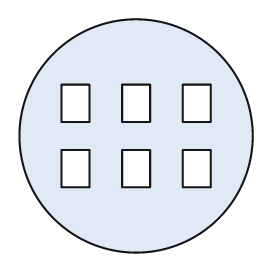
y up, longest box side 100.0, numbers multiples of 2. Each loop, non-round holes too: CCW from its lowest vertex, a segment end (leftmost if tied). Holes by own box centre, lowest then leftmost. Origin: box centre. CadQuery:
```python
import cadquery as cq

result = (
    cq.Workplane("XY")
    .moveTo(0.0, 0.0)
    .circle(50.0)
    .moveTo(-32.0, -22.0)
    .lineTo(-20.0, -22.0)
    .lineTo(-20.0, -6.0)
    .lineTo(-32.0, -6.0)
    .close()
    .moveTo(-6.0, -22.0)
    .lineTo(6.0, -22.0)
    .lineTo(6.0, -6.0)
    .lineTo(-6.0, -6.0)
    .close()
    .moveTo(20.0, -22.0)
    .lineTo(32.0, -22.0)
    .lineTo(32.0, -6.0)
    .lineTo(20.0, -6.0)
    .close()
    .moveTo(-32.0, 6.0)
    .lineTo(-20.0, 6.0)
    .lineTo(-20.0, 22.0)
    .lineTo(-32.0, 22.0)
    .close()
    .moveTo(-6.0, 6.0)
    .lineTo(6.0, 6.0)
    .lineTo(6.0, 22.0)
    .lineTo(-6.0, 22.0)
    .close()
    .moveTo(20.0, 6.0)
    .lineTo(32.0, 6.0)
    .lineTo(32.0, 22.0)
    .lineTo(20.0, 22.0)
    .close()
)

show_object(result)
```